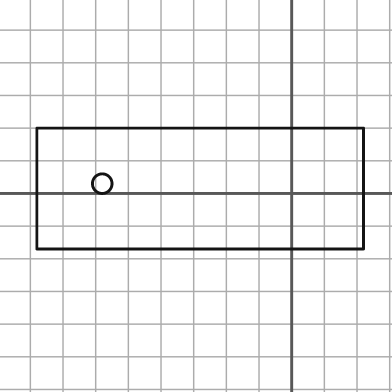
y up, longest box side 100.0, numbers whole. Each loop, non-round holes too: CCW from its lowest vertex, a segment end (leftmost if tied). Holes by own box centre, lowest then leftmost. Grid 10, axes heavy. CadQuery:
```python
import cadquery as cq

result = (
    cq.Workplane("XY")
    .moveTo(-78.0, -17.0)
    .lineTo(22.0, -17.0)
    .lineTo(22.0, 20.0)
    .lineTo(-78.0, 20.0)
    .close()
    .moveTo(-58.0, 3.0)
    .circle(3.0)
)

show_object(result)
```